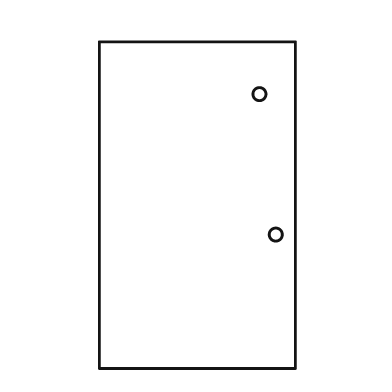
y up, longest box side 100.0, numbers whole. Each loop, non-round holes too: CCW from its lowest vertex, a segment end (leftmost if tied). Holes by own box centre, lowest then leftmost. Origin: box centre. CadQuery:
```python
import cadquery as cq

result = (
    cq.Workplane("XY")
    .moveTo(-30.0, -50.0)
    .lineTo(30.0, -50.0)
    .lineTo(30.0, 50.0)
    .lineTo(-30.0, 50.0)
    .close()
    .moveTo(24.0, -9.0)
    .circle(2.0)
    .moveTo(19.0, 34.0)
    .circle(2.0)
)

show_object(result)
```